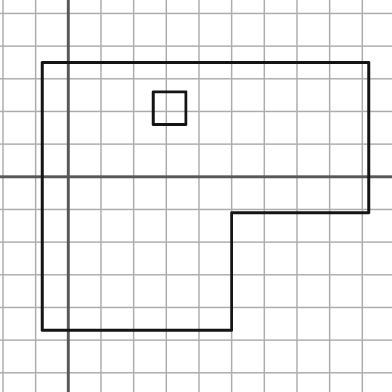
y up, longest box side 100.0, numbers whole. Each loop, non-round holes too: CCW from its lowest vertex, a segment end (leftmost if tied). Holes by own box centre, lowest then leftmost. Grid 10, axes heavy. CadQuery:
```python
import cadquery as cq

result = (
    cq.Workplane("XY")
    .moveTo(-8.0, -47.0)
    .lineTo(50.0, -47.0)
    .lineTo(50.0, -11.0)
    .lineTo(92.0, -11.0)
    .lineTo(92.0, 35.0)
    .lineTo(-8.0, 35.0)
    .close()
    .moveTo(26.0, 16.0)
    .lineTo(36.0, 16.0)
    .lineTo(36.0, 26.0)
    .lineTo(26.0, 26.0)
    .close()
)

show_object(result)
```